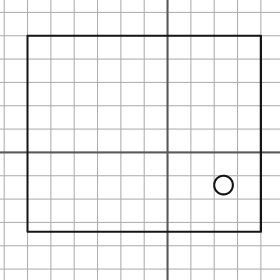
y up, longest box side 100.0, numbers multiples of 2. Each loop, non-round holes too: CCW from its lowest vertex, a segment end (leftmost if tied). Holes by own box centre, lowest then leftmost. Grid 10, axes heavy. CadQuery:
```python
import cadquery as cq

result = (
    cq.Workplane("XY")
    .moveTo(-60.0, -34.0)
    .lineTo(40.0, -34.0)
    .lineTo(40.0, 50.0)
    .lineTo(-60.0, 50.0)
    .close()
    .moveTo(24.0, -14.0)
    .circle(4.0)
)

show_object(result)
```